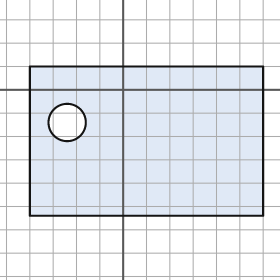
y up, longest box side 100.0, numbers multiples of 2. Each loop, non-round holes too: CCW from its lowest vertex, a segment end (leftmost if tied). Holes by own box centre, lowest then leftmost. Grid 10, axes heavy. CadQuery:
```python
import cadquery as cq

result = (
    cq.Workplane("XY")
    .moveTo(-40.0, -54.0)
    .lineTo(60.0, -54.0)
    .lineTo(60.0, 10.0)
    .lineTo(-40.0, 10.0)
    .close()
    .moveTo(-24.0, -14.0)
    .circle(8.0)
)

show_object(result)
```